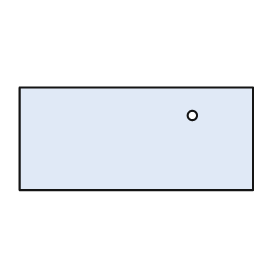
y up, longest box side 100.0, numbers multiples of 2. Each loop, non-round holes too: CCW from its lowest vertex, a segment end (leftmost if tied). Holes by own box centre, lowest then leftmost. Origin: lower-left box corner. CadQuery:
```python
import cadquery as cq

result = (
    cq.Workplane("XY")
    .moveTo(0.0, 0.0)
    .lineTo(100.0, 0.0)
    .lineTo(100.0, 44.0)
    .lineTo(0.0, 44.0)
    .close()
    .moveTo(74.0, 32.0)
    .circle(2.0)
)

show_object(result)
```